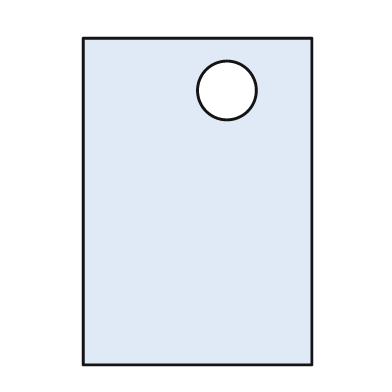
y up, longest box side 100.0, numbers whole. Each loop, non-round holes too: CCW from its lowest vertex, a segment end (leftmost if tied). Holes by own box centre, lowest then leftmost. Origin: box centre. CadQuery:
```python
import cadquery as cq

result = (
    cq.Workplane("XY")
    .moveTo(-35.0, -50.0)
    .lineTo(35.0, -50.0)
    .lineTo(35.0, 50.0)
    .lineTo(-35.0, 50.0)
    .close()
    .moveTo(9.0, 34.0)
    .circle(9.0)
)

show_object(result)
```